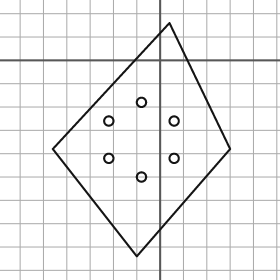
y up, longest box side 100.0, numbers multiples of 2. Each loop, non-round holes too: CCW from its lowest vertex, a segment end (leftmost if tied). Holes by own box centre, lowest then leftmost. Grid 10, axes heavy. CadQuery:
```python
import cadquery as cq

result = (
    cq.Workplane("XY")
    .moveTo(-10.0, -84.0)
    .lineTo(30.0, -38.0)
    .lineTo(4.0, 16.0)
    .lineTo(-46.0, -38.0)
    .close()
    .moveTo(-8.0, -50.0)
    .circle(2.0)
    .moveTo(-22.0, -42.0)
    .circle(2.0)
    .moveTo(6.0, -42.0)
    .circle(2.0)
    .moveTo(-22.0, -26.0)
    .circle(2.0)
    .moveTo(6.0, -26.0)
    .circle(2.0)
    .moveTo(-8.0, -18.0)
    .circle(2.0)
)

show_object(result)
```